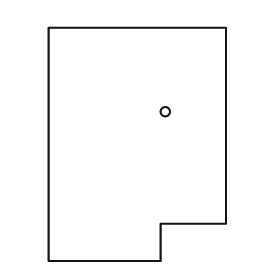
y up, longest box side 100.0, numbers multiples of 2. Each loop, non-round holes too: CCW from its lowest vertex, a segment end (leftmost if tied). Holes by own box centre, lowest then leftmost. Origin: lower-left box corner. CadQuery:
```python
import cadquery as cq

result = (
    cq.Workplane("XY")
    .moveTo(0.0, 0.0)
    .lineTo(48.0, 0.0)
    .lineTo(48.0, 16.0)
    .lineTo(76.0, 16.0)
    .lineTo(76.0, 100.0)
    .lineTo(0.0, 100.0)
    .close()
    .moveTo(50.0, 64.0)
    .circle(2.0)
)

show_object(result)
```